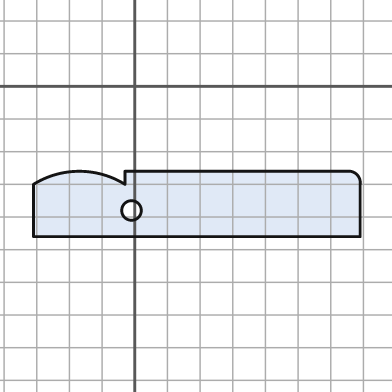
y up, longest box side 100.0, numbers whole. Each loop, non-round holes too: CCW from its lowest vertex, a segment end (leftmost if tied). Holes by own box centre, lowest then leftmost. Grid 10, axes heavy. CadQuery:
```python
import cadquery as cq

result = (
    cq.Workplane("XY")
    .moveTo(-31.0, -46.0)
    .lineTo(69.0, -46.0)
    .lineTo(69.0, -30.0)
    .threePointArc((68.0, -27.0), (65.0, -26.0))
    .lineTo(-3.0, -26.0)
    .lineTo(-3.0, -30.0)
    .threePointArc((-17.0, -26.0), (-31.0, -30.0))
    .close()
    .moveTo(-1.0, -38.0)
    .circle(3.0)
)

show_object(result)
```